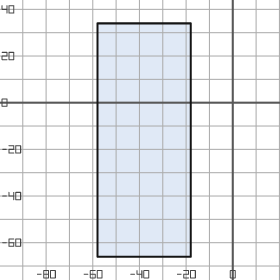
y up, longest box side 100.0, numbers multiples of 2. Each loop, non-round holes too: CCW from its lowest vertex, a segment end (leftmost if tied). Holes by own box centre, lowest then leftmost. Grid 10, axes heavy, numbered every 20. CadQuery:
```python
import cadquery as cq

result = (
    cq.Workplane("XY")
    .moveTo(-58.0, -66.0)
    .lineTo(-18.0, -66.0)
    .lineTo(-18.0, 34.0)
    .lineTo(-58.0, 34.0)
    .close()
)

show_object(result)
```